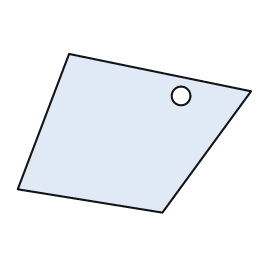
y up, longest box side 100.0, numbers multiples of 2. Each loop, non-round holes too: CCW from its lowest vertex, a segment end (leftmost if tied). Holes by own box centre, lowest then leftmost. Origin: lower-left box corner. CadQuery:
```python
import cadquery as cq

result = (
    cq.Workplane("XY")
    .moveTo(62.0, 0.0)
    .lineTo(100.0, 52.0)
    .lineTo(22.0, 68.0)
    .lineTo(0.0, 10.0)
    .close()
    .moveTo(70.0, 50.0)
    .circle(4.0)
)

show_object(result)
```